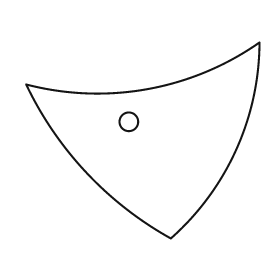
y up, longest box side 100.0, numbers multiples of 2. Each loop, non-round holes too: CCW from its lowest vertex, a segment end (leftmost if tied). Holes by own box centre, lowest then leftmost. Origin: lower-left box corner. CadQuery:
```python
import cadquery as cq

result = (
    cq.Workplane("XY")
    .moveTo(62.0, 0.0)
    .threePointArc((90.0, 38.0), (100.0, 84.0))
    .threePointArc((52.0, 64.0), (0.0, 66.0))
    .threePointArc((26.0, 28.0), (62.0, 0.0))
    .close()
    .moveTo(44.0, 50.0)
    .circle(4.0)
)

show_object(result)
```